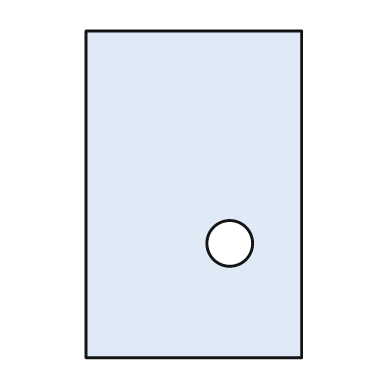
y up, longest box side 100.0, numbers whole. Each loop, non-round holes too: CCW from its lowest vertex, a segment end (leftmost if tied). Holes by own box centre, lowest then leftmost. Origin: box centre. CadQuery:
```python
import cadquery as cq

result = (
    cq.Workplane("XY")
    .moveTo(-33.0, -50.0)
    .lineTo(33.0, -50.0)
    .lineTo(33.0, 50.0)
    .lineTo(-33.0, 50.0)
    .close()
    .moveTo(11.0, -15.0)
    .circle(7.0)
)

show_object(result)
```